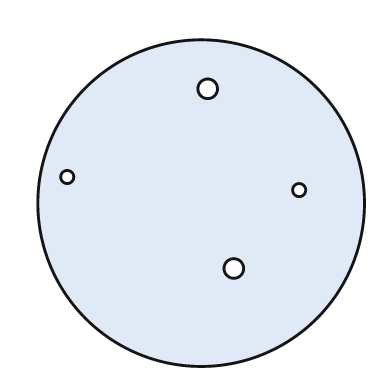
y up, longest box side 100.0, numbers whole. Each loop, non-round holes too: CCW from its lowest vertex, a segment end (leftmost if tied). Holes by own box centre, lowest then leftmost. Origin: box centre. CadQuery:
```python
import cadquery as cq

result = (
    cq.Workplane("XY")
    .moveTo(0.0, 0.0)
    .circle(50.0)
    .moveTo(10.0, -20.0)
    .circle(3.0)
    .moveTo(30.0, 4.0)
    .circle(2.0)
    .moveTo(-41.0, 8.0)
    .circle(2.0)
    .moveTo(2.0, 35.0)
    .circle(3.0)
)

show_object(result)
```